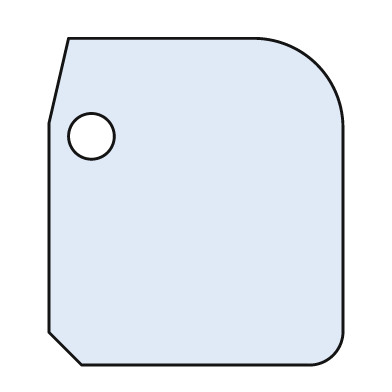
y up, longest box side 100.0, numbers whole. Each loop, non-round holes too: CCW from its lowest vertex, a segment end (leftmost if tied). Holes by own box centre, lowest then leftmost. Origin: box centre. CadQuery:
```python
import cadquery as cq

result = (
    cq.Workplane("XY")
    .moveTo(-35.0, -50.0)
    .lineTo(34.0, -50.0)
    .threePointArc((42.0, -47.0), (45.0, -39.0))
    .lineTo(45.0, 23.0)
    .threePointArc((37.0, 42.0), (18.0, 50.0))
    .lineTo(-39.0, 50.0)
    .lineTo(-45.0, 24.0)
    .lineTo(-45.0, -40.0)
    .close()
    .moveTo(-32.0, 20.0)
    .circle(7.0)
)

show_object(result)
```